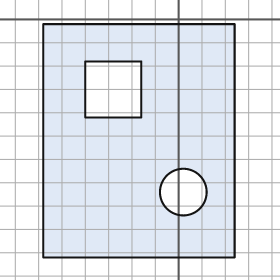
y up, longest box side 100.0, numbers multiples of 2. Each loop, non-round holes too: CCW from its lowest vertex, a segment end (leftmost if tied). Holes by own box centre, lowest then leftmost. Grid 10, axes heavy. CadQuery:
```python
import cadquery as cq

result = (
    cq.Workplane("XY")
    .moveTo(-58.0, -102.0)
    .lineTo(24.0, -102.0)
    .lineTo(24.0, -2.0)
    .lineTo(-58.0, -2.0)
    .close()
    .moveTo(2.0, -74.0)
    .circle(10.0)
    .moveTo(-40.0, -42.0)
    .lineTo(-16.0, -42.0)
    .lineTo(-16.0, -18.0)
    .lineTo(-40.0, -18.0)
    .close()
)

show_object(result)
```